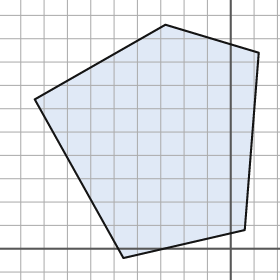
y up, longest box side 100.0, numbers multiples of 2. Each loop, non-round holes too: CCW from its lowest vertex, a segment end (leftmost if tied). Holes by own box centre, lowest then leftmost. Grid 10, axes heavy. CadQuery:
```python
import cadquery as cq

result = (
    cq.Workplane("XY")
    .moveTo(-46.0, -4.0)
    .lineTo(6.0, 8.0)
    .lineTo(12.0, 84.0)
    .lineTo(-28.0, 96.0)
    .lineTo(-84.0, 64.0)
    .close()
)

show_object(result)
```